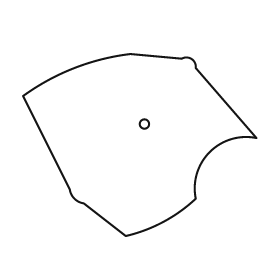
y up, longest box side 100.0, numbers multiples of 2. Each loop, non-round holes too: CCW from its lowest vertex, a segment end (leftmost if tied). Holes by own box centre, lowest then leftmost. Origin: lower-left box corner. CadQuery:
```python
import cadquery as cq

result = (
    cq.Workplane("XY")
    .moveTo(44.0, 0.0)
    .threePointArc((60.0, 6.0), (74.0, 16.0))
    .threePointArc((80.0, 36.0), (100.0, 42.0))
    .lineTo(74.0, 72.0)
    .threePointArc((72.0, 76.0), (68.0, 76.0))
    .lineTo(46.0, 78.0)
    .threePointArc((22.0, 72.0), (0.0, 60.0))
    .lineTo(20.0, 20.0)
    .threePointArc((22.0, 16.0), (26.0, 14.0))
    .close()
    .moveTo(52.0, 48.0)
    .circle(2.0)
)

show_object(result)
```